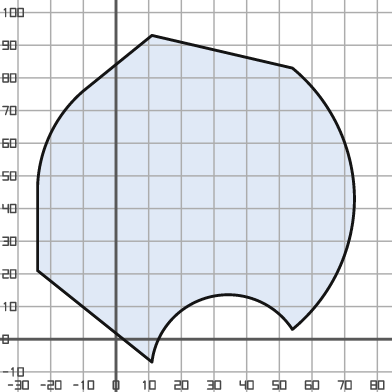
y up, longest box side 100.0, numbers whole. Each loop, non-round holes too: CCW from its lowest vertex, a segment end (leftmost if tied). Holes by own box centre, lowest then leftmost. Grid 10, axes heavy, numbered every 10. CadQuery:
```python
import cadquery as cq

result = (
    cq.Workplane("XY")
    .moveTo(11.0, -7.0)
    .threePointArc((29.0, 13.0), (54.0, 3.0))
    .threePointArc((68.0, 21.0), (73.0, 43.0))
    .threePointArc((68.0, 65.0), (54.0, 83.0))
    .lineTo(11.0, 93.0)
    .lineTo(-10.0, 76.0)
    .threePointArc((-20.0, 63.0), (-24.0, 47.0))
    .lineTo(-24.0, 21.0)
    .close()
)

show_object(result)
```